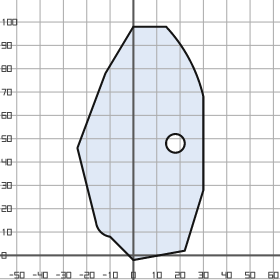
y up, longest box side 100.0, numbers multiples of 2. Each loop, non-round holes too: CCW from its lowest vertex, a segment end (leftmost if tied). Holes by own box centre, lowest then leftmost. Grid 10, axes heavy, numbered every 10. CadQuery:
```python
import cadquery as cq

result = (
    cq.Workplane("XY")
    .moveTo(0.0, -2.0)
    .lineTo(22.0, 2.0)
    .lineTo(30.0, 28.0)
    .lineTo(30.0, 68.0)
    .threePointArc((24.0, 84.0), (14.0, 98.0))
    .lineTo(0.0, 98.0)
    .lineTo(-12.0, 78.0)
    .lineTo(-24.0, 46.0)
    .lineTo(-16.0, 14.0)
    .threePointArc((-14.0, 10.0), (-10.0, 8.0))
    .close()
    .moveTo(18.0, 48.0)
    .circle(4.0)
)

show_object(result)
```